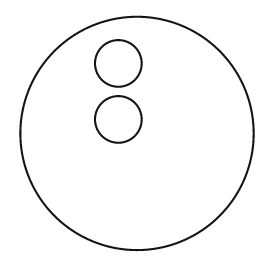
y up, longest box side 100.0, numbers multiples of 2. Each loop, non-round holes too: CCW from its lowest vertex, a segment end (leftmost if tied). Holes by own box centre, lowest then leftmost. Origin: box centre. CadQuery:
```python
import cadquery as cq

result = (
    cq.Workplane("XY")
    .moveTo(0.0, 0.0)
    .circle(50.0)
    .moveTo(-8.0, 6.0)
    .circle(10.0)
    .moveTo(-8.0, 30.0)
    .circle(10.0)
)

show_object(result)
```